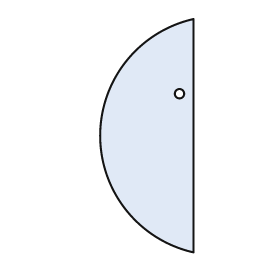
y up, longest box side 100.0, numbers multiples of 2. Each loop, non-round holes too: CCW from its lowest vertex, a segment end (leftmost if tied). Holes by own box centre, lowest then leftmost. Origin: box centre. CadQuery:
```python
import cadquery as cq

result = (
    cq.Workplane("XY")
    .moveTo(20.0, -50.0)
    .lineTo(20.0, 50.0)
    .threePointArc((-20.0, 0.0), (20.0, -50.0))
    .close()
    .moveTo(14.0, 18.0)
    .circle(2.0)
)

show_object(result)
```